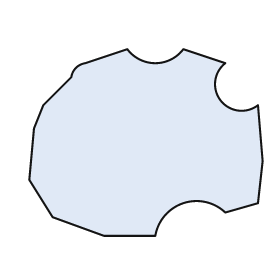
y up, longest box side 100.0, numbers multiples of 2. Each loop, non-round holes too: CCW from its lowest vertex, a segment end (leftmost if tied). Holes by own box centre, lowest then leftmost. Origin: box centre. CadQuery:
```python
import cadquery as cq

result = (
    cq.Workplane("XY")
    .moveTo(-18.0, -40.0)
    .lineTo(4.0, -40.0)
    .threePointArc((16.0, -26.0), (34.0, -30.0))
    .lineTo(48.0, -26.0)
    .lineTo(50.0, -8.0)
    .lineTo(48.0, 16.0)
    .threePointArc((32.0, 18.0), (34.0, 34.0))
    .lineTo(16.0, 40.0)
    .threePointArc((4.0, 34.0), (-8.0, 40.0))
    .lineTo(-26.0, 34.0)
    .threePointArc((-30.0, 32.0), (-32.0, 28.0))
    .lineTo(-44.0, 16.0)
    .lineTo(-48.0, 6.0)
    .lineTo(-50.0, -16.0)
    .lineTo(-40.0, -32.0)
    .close()
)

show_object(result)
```